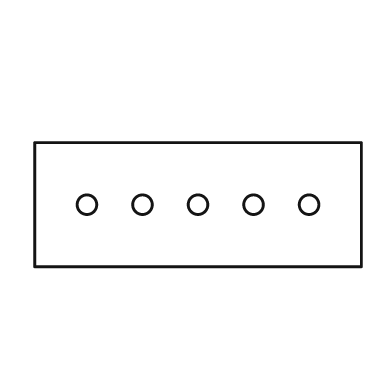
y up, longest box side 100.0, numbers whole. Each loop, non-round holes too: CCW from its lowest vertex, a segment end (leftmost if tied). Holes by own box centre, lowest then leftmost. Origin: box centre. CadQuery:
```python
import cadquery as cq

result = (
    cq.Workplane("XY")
    .moveTo(-50.0, -19.0)
    .lineTo(50.0, -19.0)
    .lineTo(50.0, 19.0)
    .lineTo(-50.0, 19.0)
    .close()
    .moveTo(-34.0, 0.0)
    .circle(3.0)
    .moveTo(-17.0, 0.0)
    .circle(3.0)
    .moveTo(0.0, 0.0)
    .circle(3.0)
    .moveTo(17.0, 0.0)
    .circle(3.0)
    .moveTo(34.0, 0.0)
    .circle(3.0)
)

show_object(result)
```